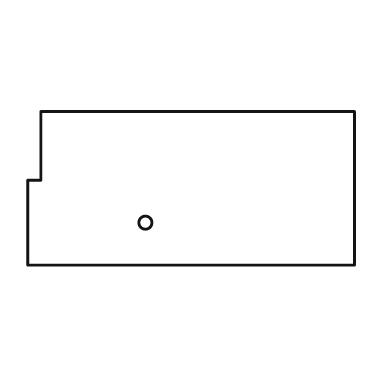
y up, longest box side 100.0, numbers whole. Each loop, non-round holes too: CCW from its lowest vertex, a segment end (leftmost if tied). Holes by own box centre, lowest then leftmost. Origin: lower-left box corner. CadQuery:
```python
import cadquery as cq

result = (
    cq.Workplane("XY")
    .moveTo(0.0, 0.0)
    .lineTo(100.0, 0.0)
    .lineTo(100.0, 47.0)
    .lineTo(4.0, 47.0)
    .lineTo(4.0, 26.0)
    .lineTo(0.0, 26.0)
    .close()
    .moveTo(36.0, 13.0)
    .circle(2.0)
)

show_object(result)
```